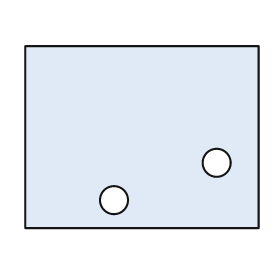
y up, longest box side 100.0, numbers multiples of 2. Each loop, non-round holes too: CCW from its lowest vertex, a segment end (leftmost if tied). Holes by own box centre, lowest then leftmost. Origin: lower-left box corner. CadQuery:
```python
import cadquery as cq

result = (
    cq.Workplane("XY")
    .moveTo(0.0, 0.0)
    .lineTo(100.0, 0.0)
    .lineTo(100.0, 78.0)
    .lineTo(0.0, 78.0)
    .close()
    .moveTo(38.0, 12.0)
    .circle(6.0)
    .moveTo(82.0, 28.0)
    .circle(6.0)
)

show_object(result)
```